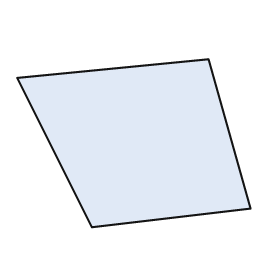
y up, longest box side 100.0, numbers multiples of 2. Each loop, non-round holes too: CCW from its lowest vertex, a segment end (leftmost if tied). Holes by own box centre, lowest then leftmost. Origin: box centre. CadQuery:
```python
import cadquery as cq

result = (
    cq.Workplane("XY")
    .moveTo(-18.0, -36.0)
    .lineTo(50.0, -28.0)
    .lineTo(32.0, 36.0)
    .lineTo(-50.0, 28.0)
    .close()
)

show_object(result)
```